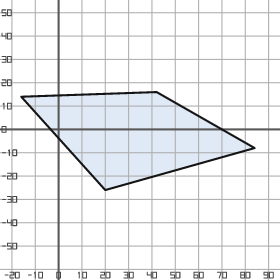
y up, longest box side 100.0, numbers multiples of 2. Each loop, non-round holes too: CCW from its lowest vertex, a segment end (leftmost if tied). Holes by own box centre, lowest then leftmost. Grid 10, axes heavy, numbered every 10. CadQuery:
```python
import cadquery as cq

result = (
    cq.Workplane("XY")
    .moveTo(20.0, -26.0)
    .lineTo(84.0, -8.0)
    .lineTo(42.0, 16.0)
    .lineTo(-16.0, 14.0)
    .close()
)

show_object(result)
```